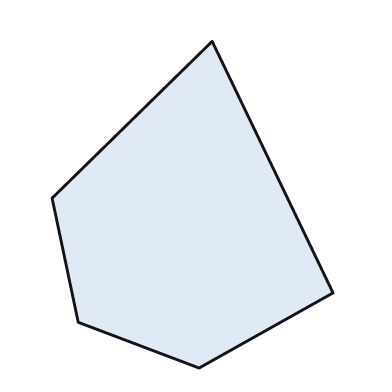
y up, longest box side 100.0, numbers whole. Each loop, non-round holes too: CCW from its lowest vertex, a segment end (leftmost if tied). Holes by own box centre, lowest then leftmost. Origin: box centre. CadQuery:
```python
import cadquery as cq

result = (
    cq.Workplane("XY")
    .moveTo(2.0, -50.0)
    .lineTo(43.0, -27.0)
    .lineTo(6.0, 50.0)
    .lineTo(-43.0, 2.0)
    .lineTo(-35.0, -36.0)
    .close()
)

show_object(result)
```